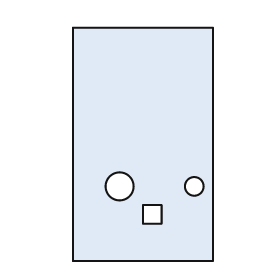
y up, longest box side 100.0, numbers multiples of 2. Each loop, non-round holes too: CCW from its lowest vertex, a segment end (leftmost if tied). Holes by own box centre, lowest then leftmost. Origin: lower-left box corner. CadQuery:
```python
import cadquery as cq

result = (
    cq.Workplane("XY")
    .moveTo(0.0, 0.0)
    .lineTo(60.0, 0.0)
    .lineTo(60.0, 100.0)
    .lineTo(0.0, 100.0)
    .close()
    .moveTo(30.0, 16.0)
    .lineTo(38.0, 16.0)
    .lineTo(38.0, 24.0)
    .lineTo(30.0, 24.0)
    .close()
    .moveTo(20.0, 32.0)
    .circle(6.0)
    .moveTo(52.0, 32.0)
    .circle(4.0)
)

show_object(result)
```